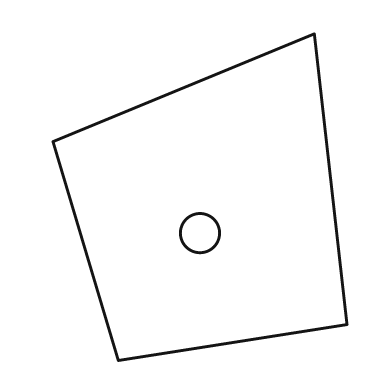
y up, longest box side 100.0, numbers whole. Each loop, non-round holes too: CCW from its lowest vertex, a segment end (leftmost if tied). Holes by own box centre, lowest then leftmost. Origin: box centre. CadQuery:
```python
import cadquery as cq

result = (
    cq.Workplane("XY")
    .moveTo(-25.0, -50.0)
    .lineTo(45.0, -39.0)
    .lineTo(35.0, 50.0)
    .lineTo(-45.0, 17.0)
    .close()
    .moveTo(0.0, -11.0)
    .circle(6.0)
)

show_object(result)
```